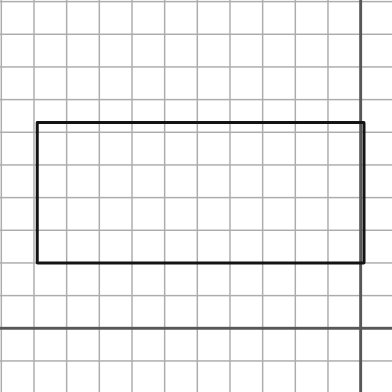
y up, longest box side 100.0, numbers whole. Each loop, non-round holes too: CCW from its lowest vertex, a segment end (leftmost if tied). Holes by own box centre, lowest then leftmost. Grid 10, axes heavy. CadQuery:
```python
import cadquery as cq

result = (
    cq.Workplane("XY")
    .moveTo(-99.0, 20.0)
    .lineTo(1.0, 20.0)
    .lineTo(1.0, 63.0)
    .lineTo(-99.0, 63.0)
    .close()
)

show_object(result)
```